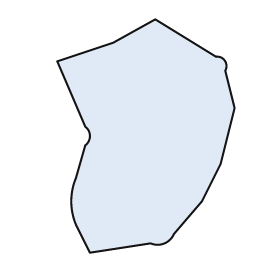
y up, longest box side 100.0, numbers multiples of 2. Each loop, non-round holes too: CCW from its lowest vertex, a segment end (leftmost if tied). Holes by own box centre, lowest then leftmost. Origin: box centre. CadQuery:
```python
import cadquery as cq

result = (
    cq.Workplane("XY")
    .moveTo(-24.0, -50.0)
    .lineTo(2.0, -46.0)
    .threePointArc((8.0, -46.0), (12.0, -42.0))
    .lineTo(24.0, -28.0)
    .lineTo(32.0, -12.0)
    .lineTo(38.0, 12.0)
    .lineTo(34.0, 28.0)
    .threePointArc((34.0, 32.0), (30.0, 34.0))
    .lineTo(4.0, 50.0)
    .lineTo(-14.0, 40.0)
    .lineTo(-38.0, 32.0)
    .lineTo(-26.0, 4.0)
    .threePointArc((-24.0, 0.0), (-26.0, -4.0))
    .lineTo(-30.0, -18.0)
    .threePointArc((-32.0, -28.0), (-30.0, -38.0))
    .close()
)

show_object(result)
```